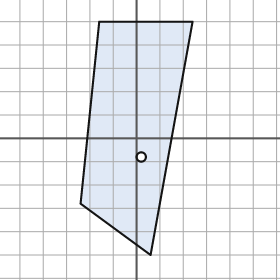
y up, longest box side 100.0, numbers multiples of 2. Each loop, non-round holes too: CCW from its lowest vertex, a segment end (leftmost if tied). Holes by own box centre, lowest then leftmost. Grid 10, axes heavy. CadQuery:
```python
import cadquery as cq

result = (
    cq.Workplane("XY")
    .moveTo(6.0, -50.0)
    .lineTo(24.0, 50.0)
    .lineTo(-16.0, 50.0)
    .lineTo(-24.0, -28.0)
    .close()
    .moveTo(2.0, -8.0)
    .circle(2.0)
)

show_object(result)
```